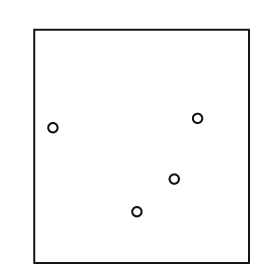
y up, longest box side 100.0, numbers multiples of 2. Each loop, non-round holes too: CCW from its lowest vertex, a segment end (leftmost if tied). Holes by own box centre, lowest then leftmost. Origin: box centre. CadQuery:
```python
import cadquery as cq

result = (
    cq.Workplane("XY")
    .moveTo(-46.0, -50.0)
    .lineTo(46.0, -50.0)
    .lineTo(46.0, 50.0)
    .lineTo(-46.0, 50.0)
    .close()
    .moveTo(-2.0, -28.0)
    .circle(2.0)
    .moveTo(14.0, -14.0)
    .circle(2.0)
    .moveTo(-38.0, 8.0)
    .circle(2.0)
    .moveTo(24.0, 12.0)
    .circle(2.0)
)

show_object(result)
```